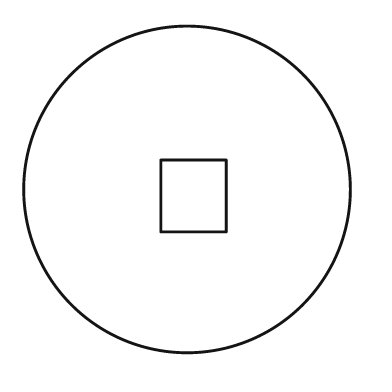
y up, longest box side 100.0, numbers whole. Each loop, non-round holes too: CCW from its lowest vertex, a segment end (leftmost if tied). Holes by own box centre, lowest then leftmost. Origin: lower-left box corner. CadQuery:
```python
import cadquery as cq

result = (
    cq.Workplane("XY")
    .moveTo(50.0, 50.0)
    .circle(50.0)
    .moveTo(42.0, 37.0)
    .lineTo(62.0, 37.0)
    .lineTo(62.0, 59.0)
    .lineTo(42.0, 59.0)
    .close()
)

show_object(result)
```